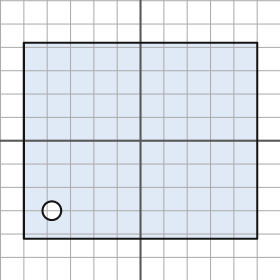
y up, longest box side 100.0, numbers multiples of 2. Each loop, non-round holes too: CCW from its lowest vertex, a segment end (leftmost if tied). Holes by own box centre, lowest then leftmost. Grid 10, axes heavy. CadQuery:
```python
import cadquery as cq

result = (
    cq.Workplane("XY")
    .moveTo(-50.0, -42.0)
    .lineTo(50.0, -42.0)
    .lineTo(50.0, 42.0)
    .lineTo(-50.0, 42.0)
    .close()
    .moveTo(-38.0, -30.0)
    .circle(4.0)
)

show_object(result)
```